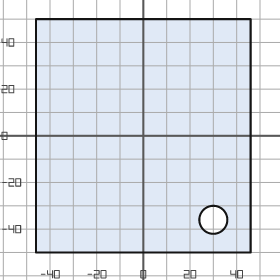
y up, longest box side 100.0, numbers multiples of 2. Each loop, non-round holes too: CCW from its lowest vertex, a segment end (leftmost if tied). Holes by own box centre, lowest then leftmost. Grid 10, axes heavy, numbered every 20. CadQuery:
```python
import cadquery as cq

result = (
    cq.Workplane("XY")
    .moveTo(-46.0, -50.0)
    .lineTo(46.0, -50.0)
    .lineTo(46.0, 50.0)
    .lineTo(-46.0, 50.0)
    .close()
    .moveTo(30.0, -36.0)
    .circle(6.0)
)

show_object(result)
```